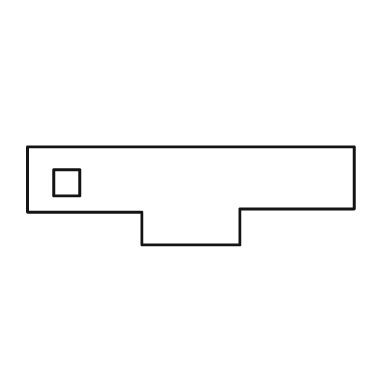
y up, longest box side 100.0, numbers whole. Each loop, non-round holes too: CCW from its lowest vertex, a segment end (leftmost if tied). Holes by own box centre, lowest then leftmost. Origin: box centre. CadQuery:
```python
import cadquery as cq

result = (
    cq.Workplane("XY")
    .moveTo(-15.0, -15.0)
    .lineTo(15.0, -15.0)
    .lineTo(15.0, -4.0)
    .lineTo(50.0, -4.0)
    .lineTo(50.0, 15.0)
    .lineTo(-50.0, 15.0)
    .lineTo(-50.0, -5.0)
    .lineTo(-15.0, -5.0)
    .close()
    .moveTo(-42.0, 0.0)
    .lineTo(-34.0, 0.0)
    .lineTo(-34.0, 8.0)
    .lineTo(-42.0, 8.0)
    .close()
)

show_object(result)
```